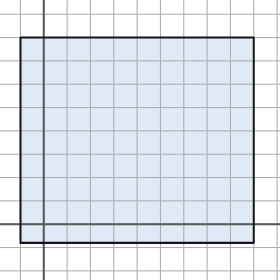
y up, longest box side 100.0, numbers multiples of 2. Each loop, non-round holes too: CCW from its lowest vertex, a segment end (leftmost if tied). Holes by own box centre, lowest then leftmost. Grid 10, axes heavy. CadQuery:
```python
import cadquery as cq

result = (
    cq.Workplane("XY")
    .moveTo(-10.0, -8.0)
    .lineTo(90.0, -8.0)
    .lineTo(90.0, 80.0)
    .lineTo(-10.0, 80.0)
    .close()
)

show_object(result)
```